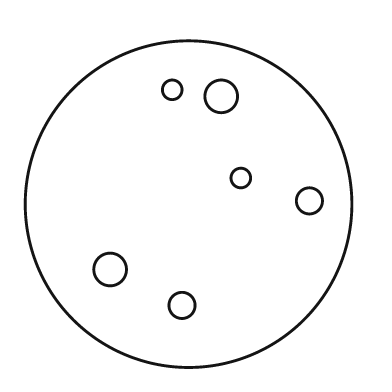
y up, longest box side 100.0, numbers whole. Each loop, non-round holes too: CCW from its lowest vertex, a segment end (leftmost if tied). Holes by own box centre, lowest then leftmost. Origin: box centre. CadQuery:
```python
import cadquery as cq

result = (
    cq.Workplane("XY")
    .moveTo(0.0, 0.0)
    .circle(50.0)
    .moveTo(-2.0, -31.0)
    .circle(4.0)
    .moveTo(-24.0, -20.0)
    .circle(5.0)
    .moveTo(37.0, 1.0)
    .circle(4.0)
    .moveTo(16.0, 8.0)
    .circle(3.0)
    .moveTo(10.0, 33.0)
    .circle(5.0)
    .moveTo(-5.0, 35.0)
    .circle(3.0)
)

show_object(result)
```